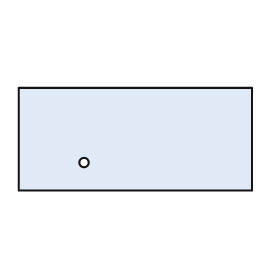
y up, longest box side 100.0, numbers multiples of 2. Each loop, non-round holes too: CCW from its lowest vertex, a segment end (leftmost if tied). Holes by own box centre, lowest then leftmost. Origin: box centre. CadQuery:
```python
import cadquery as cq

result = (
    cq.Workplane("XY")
    .moveTo(-50.0, -22.0)
    .lineTo(50.0, -22.0)
    .lineTo(50.0, 22.0)
    .lineTo(-50.0, 22.0)
    .close()
    .moveTo(-22.0, -10.0)
    .circle(2.0)
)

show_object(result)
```